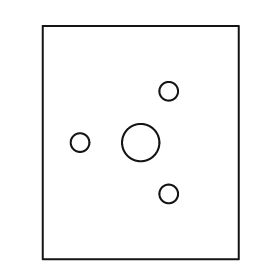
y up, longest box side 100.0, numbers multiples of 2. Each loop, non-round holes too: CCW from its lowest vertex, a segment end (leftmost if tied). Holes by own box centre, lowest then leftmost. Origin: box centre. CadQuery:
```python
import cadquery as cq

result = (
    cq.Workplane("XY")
    .moveTo(-42.0, -50.0)
    .lineTo(42.0, -50.0)
    .lineTo(42.0, 50.0)
    .lineTo(-42.0, 50.0)
    .close()
    .moveTo(12.0, -22.0)
    .circle(4.0)
    .moveTo(-26.0, 0.0)
    .circle(4.0)
    .moveTo(0.0, 0.0)
    .circle(8.0)
    .moveTo(12.0, 22.0)
    .circle(4.0)
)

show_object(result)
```